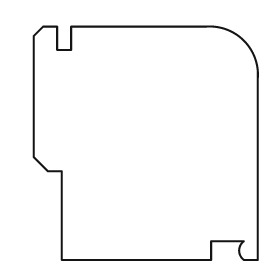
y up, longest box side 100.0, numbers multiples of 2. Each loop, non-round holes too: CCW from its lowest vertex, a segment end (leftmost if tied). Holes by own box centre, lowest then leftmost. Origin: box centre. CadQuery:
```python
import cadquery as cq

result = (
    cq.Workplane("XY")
    .moveTo(-36.0, -50.0)
    .lineTo(28.0, -50.0)
    .lineTo(28.0, -42.0)
    .lineTo(42.0, -42.0)
    .threePointArc((40.0, -46.0), (42.0, -50.0))
    .lineTo(48.0, -50.0)
    .lineTo(48.0, 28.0)
    .threePointArc((42.0, 44.0), (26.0, 50.0))
    .lineTo(-32.0, 50.0)
    .lineTo(-32.0, 40.0)
    .lineTo(-38.0, 40.0)
    .lineTo(-38.0, 50.0)
    .lineTo(-44.0, 50.0)
    .lineTo(-48.0, 46.0)
    .lineTo(-48.0, -6.0)
    .lineTo(-42.0, -12.0)
    .lineTo(-36.0, -12.0)
    .close()
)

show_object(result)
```